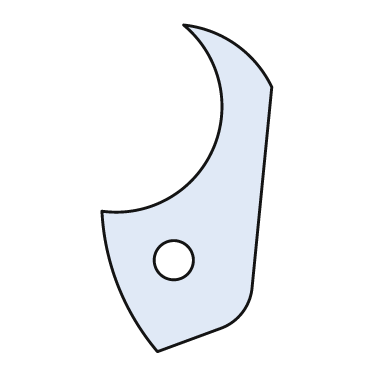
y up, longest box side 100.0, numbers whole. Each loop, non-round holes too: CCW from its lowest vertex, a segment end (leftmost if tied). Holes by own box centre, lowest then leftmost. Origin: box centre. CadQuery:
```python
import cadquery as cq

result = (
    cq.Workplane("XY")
    .moveTo(-9.0, -50.0)
    .lineTo(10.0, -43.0)
    .threePointArc((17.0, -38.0), (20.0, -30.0))
    .lineTo(26.0, 31.0)
    .threePointArc((15.0, 44.0), (-1.0, 50.0))
    .threePointArc((8.0, 12.0), (-26.0, -7.0))
    .threePointArc((-21.0, -30.0), (-9.0, -50.0))
    .close()
    .moveTo(-4.0, -22.0)
    .circle(6.0)
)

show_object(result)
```